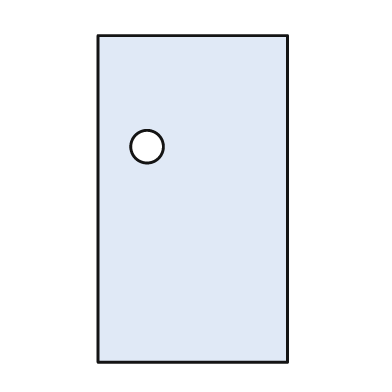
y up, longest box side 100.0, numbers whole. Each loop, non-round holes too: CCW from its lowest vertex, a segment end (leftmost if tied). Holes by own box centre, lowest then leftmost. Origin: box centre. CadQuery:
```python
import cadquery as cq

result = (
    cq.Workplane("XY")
    .moveTo(-29.0, -50.0)
    .lineTo(29.0, -50.0)
    .lineTo(29.0, 50.0)
    .lineTo(-29.0, 50.0)
    .close()
    .moveTo(-14.0, 16.0)
    .circle(5.0)
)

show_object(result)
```